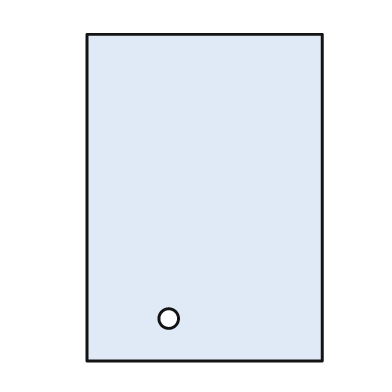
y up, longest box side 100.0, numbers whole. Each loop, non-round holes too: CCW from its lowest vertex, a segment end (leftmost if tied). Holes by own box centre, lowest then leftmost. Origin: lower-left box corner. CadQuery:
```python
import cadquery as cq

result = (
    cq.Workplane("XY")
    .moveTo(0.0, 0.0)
    .lineTo(72.0, 0.0)
    .lineTo(72.0, 100.0)
    .lineTo(0.0, 100.0)
    .close()
    .moveTo(25.0, 13.0)
    .circle(3.0)
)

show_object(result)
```